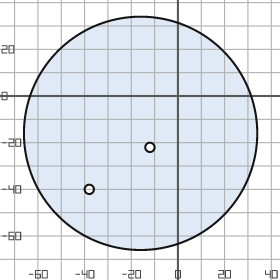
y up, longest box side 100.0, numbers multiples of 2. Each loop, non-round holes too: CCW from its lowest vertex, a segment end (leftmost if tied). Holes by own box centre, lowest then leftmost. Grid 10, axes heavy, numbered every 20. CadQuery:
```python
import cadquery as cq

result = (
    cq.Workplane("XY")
    .moveTo(-16.0, -16.0)
    .circle(50.0)
    .moveTo(-38.0, -40.0)
    .circle(2.0)
    .moveTo(-12.0, -22.0)
    .circle(2.0)
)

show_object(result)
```